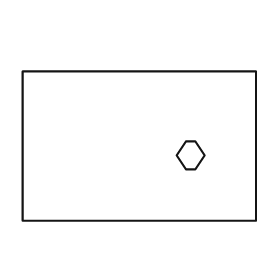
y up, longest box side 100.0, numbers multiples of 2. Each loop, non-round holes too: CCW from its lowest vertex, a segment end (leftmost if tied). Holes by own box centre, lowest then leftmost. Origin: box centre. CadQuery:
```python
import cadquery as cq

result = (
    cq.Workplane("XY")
    .moveTo(-50.0, -32.0)
    .lineTo(50.0, -32.0)
    .lineTo(50.0, 32.0)
    .lineTo(-50.0, 32.0)
    .close()
    .moveTo(20.0, -10.0)
    .lineTo(24.0, -10.0)
    .lineTo(28.0, -4.0)
    .lineTo(24.0, 2.0)
    .lineTo(20.0, 2.0)
    .lineTo(16.0, -4.0)
    .close()
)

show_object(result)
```